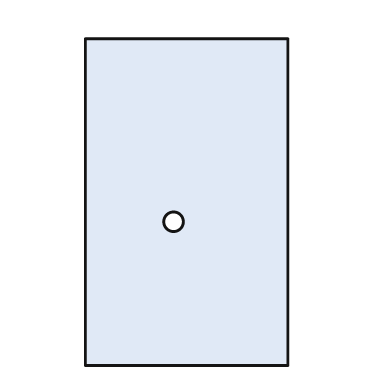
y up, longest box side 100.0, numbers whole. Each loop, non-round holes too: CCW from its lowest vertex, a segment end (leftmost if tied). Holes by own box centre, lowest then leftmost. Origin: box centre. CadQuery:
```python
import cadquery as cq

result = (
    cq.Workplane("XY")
    .moveTo(-31.0, -50.0)
    .lineTo(31.0, -50.0)
    .lineTo(31.0, 50.0)
    .lineTo(-31.0, 50.0)
    .close()
    .moveTo(-4.0, -6.0)
    .circle(3.0)
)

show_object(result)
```